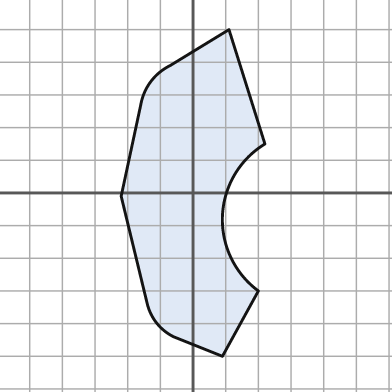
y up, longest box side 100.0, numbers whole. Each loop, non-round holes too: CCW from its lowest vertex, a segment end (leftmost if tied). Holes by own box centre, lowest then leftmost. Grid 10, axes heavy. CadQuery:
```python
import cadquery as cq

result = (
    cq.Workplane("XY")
    .moveTo(9.0, -50.0)
    .lineTo(20.0, -30.0)
    .threePointArc((9.0, -7.0), (22.0, 15.0))
    .lineTo(11.0, 50.0)
    .lineTo(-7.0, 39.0)
    .threePointArc((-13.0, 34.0), (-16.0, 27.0))
    .lineTo(-22.0, -1.0)
    .lineTo(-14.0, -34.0)
    .threePointArc((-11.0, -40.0), (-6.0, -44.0))
    .close()
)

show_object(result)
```